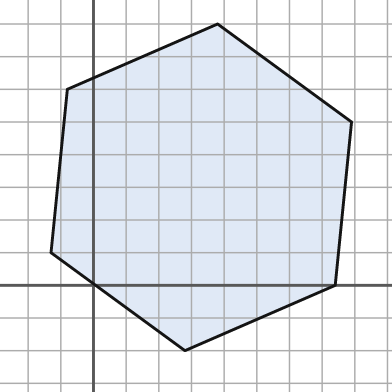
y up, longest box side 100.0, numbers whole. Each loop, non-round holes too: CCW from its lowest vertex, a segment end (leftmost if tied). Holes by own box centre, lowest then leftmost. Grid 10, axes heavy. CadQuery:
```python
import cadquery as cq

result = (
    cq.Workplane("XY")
    .moveTo(28.0, -20.0)
    .lineTo(74.0, 0.0)
    .lineTo(79.0, 50.0)
    .lineTo(38.0, 80.0)
    .lineTo(-8.0, 60.0)
    .lineTo(-13.0, 10.0)
    .close()
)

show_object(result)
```